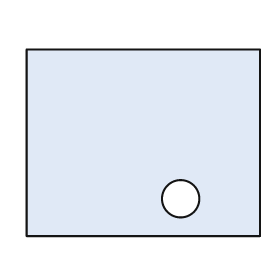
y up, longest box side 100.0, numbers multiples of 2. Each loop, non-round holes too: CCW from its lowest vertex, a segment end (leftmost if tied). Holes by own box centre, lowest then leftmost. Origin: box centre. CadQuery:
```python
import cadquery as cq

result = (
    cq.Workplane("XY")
    .moveTo(-50.0, -40.0)
    .lineTo(50.0, -40.0)
    .lineTo(50.0, 40.0)
    .lineTo(-50.0, 40.0)
    .close()
    .moveTo(16.0, -24.0)
    .circle(8.0)
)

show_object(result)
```